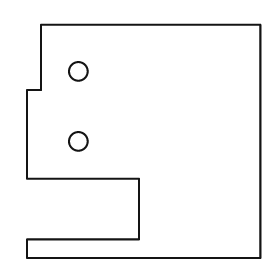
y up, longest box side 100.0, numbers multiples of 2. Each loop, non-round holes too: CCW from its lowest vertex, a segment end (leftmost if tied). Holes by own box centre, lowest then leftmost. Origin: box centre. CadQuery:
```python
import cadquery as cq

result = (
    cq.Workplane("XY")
    .moveTo(-50.0, -50.0)
    .lineTo(50.0, -50.0)
    .lineTo(50.0, 50.0)
    .lineTo(-44.0, 50.0)
    .lineTo(-44.0, 22.0)
    .lineTo(-50.0, 22.0)
    .lineTo(-50.0, -16.0)
    .lineTo(-2.0, -16.0)
    .lineTo(-2.0, -42.0)
    .lineTo(-50.0, -42.0)
    .close()
    .moveTo(-28.0, 0.0)
    .circle(4.0)
    .moveTo(-28.0, 30.0)
    .circle(4.0)
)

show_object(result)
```